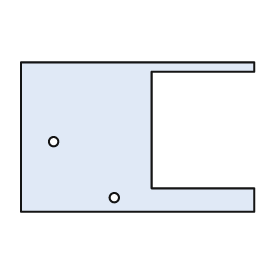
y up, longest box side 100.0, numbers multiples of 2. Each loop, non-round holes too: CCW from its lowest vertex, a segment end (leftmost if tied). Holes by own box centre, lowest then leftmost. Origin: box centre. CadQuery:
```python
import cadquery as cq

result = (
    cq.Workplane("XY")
    .moveTo(-50.0, -32.0)
    .lineTo(50.0, -32.0)
    .lineTo(50.0, -22.0)
    .lineTo(6.0, -22.0)
    .lineTo(6.0, 28.0)
    .lineTo(50.0, 28.0)
    .lineTo(50.0, 32.0)
    .lineTo(-50.0, 32.0)
    .close()
    .moveTo(-10.0, -26.0)
    .circle(2.0)
    .moveTo(-36.0, -2.0)
    .circle(2.0)
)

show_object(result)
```